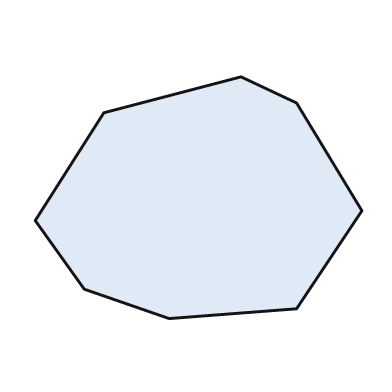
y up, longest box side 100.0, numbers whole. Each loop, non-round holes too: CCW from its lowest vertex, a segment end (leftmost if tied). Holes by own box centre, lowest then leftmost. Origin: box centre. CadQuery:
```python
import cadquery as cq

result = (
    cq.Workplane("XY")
    .moveTo(-9.0, -37.0)
    .lineTo(30.0, -34.0)
    .lineTo(50.0, -4.0)
    .lineTo(30.0, 29.0)
    .lineTo(13.0, 37.0)
    .lineTo(-29.0, 26.0)
    .lineTo(-50.0, -7.0)
    .lineTo(-35.0, -28.0)
    .close()
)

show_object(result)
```